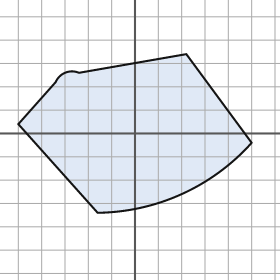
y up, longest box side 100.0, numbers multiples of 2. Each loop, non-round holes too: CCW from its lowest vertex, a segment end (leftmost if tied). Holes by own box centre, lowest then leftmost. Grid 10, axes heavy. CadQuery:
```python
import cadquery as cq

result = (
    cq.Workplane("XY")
    .moveTo(-16.0, -34.0)
    .threePointArc((20.0, -26.0), (50.0, -4.0))
    .lineTo(22.0, 34.0)
    .lineTo(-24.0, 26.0)
    .threePointArc((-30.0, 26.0), (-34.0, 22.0))
    .lineTo(-50.0, 4.0)
    .close()
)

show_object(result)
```